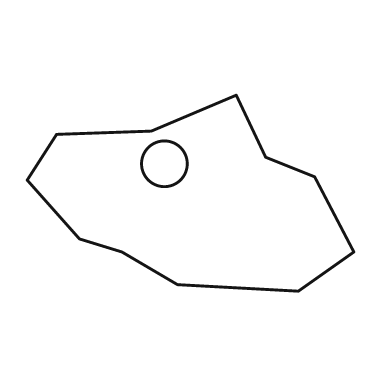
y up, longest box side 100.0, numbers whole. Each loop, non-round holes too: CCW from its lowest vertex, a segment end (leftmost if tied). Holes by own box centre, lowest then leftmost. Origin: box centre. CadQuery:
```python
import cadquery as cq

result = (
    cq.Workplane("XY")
    .moveTo(33.0, -30.0)
    .lineTo(50.0, -18.0)
    .lineTo(38.0, 5.0)
    .lineTo(23.0, 11.0)
    .lineTo(14.0, 30.0)
    .lineTo(-12.0, 19.0)
    .lineTo(-41.0, 18.0)
    .lineTo(-50.0, 4.0)
    .lineTo(-34.0, -14.0)
    .lineTo(-21.0, -18.0)
    .lineTo(-4.0, -28.0)
    .close()
    .moveTo(-8.0, 9.0)
    .circle(7.0)
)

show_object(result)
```